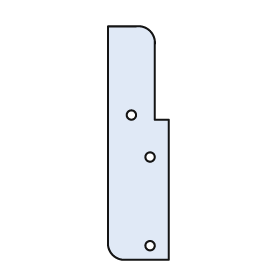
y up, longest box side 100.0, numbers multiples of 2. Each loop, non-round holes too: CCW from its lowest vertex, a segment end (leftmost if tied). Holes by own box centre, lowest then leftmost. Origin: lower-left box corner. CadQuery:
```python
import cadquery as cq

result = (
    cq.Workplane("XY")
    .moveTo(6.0, 0.0)
    .lineTo(26.0, 0.0)
    .lineTo(26.0, 60.0)
    .lineTo(20.0, 60.0)
    .lineTo(20.0, 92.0)
    .threePointArc((18.0, 98.0), (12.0, 100.0))
    .lineTo(0.0, 100.0)
    .lineTo(0.0, 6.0)
    .threePointArc((2.0, 2.0), (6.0, 0.0))
    .close()
    .moveTo(18.0, 6.0)
    .circle(2.0)
    .moveTo(18.0, 44.0)
    .circle(2.0)
    .moveTo(10.0, 62.0)
    .circle(2.0)
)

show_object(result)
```